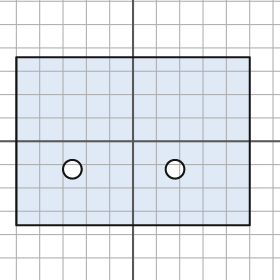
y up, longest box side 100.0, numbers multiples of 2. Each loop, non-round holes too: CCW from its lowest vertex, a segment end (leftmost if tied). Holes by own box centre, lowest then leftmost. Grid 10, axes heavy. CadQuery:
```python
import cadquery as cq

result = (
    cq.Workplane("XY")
    .moveTo(-50.0, -36.0)
    .lineTo(50.0, -36.0)
    .lineTo(50.0, 36.0)
    .lineTo(-50.0, 36.0)
    .close()
    .moveTo(-26.0, -12.0)
    .circle(4.0)
    .moveTo(18.0, -12.0)
    .circle(4.0)
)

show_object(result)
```